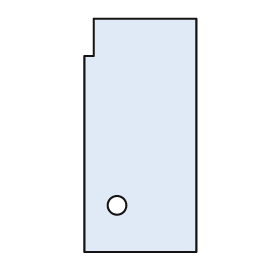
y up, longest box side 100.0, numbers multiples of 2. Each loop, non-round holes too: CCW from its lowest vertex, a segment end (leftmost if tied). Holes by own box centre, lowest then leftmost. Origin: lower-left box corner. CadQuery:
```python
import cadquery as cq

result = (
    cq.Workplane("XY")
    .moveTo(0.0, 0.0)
    .lineTo(48.0, 0.0)
    .lineTo(48.0, 100.0)
    .lineTo(4.0, 100.0)
    .lineTo(4.0, 84.0)
    .lineTo(0.0, 84.0)
    .close()
    .moveTo(14.0, 20.0)
    .circle(4.0)
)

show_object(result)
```